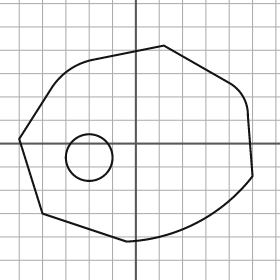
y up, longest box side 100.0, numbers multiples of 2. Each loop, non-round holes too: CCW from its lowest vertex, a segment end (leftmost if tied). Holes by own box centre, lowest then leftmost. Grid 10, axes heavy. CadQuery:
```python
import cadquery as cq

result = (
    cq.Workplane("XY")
    .moveTo(-4.0, -42.0)
    .threePointArc((26.0, -34.0), (50.0, -14.0))
    .lineTo(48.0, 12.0)
    .threePointArc((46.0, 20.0), (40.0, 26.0))
    .lineTo(12.0, 42.0)
    .lineTo(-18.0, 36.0)
    .threePointArc((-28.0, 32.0), (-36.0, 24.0))
    .lineTo(-50.0, 2.0)
    .lineTo(-40.0, -30.0)
    .close()
    .moveTo(-20.0, -6.0)
    .circle(10.0)
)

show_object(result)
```